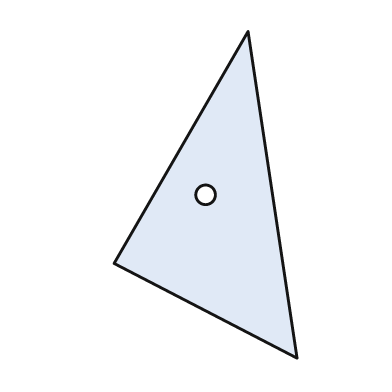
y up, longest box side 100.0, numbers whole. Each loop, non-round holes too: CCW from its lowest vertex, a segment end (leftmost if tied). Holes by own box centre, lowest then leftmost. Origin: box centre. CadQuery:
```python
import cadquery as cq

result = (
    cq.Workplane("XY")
    .moveTo(28.0, -50.0)
    .lineTo(13.0, 50.0)
    .lineTo(-28.0, -21.0)
    .close()
    .moveTo(0.0, 0.0)
    .circle(3.0)
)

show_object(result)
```